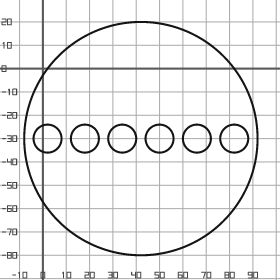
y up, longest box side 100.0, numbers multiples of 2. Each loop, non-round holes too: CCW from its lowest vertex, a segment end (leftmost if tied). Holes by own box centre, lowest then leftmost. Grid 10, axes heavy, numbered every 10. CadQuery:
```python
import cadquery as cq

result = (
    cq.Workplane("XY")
    .moveTo(42.0, -30.0)
    .circle(50.0)
    .moveTo(2.0, -30.0)
    .circle(6.0)
    .moveTo(18.0, -30.0)
    .circle(6.0)
    .moveTo(34.0, -30.0)
    .circle(6.0)
    .moveTo(50.0, -30.0)
    .circle(6.0)
    .moveTo(66.0, -30.0)
    .circle(6.0)
    .moveTo(82.0, -30.0)
    .circle(6.0)
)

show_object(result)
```